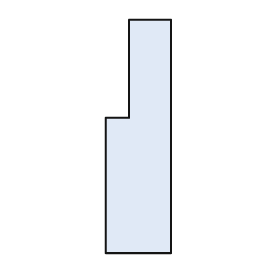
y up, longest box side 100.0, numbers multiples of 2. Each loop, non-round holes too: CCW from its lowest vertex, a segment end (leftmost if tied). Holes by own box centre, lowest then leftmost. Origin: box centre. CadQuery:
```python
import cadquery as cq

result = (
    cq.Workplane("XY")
    .moveTo(-14.0, -50.0)
    .lineTo(14.0, -50.0)
    .lineTo(14.0, 50.0)
    .lineTo(-4.0, 50.0)
    .lineTo(-4.0, 8.0)
    .lineTo(-14.0, 8.0)
    .close()
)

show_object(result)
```